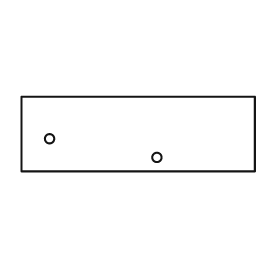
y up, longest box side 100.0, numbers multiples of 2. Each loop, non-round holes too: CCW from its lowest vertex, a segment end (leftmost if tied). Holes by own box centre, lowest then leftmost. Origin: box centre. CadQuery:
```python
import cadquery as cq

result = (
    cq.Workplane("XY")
    .moveTo(-50.0, -16.0)
    .lineTo(50.0, -16.0)
    .lineTo(50.0, 16.0)
    .lineTo(-50.0, 16.0)
    .close()
    .moveTo(8.0, -10.0)
    .circle(2.0)
    .moveTo(-38.0, -2.0)
    .circle(2.0)
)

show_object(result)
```